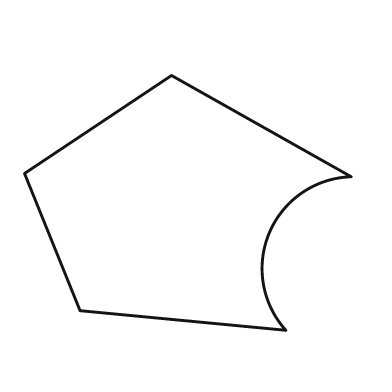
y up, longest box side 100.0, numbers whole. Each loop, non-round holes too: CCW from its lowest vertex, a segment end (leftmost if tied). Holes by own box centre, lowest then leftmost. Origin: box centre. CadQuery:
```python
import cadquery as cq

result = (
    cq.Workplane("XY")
    .moveTo(30.0, -39.0)
    .threePointArc((25.0, -9.0), (50.0, 8.0))
    .lineTo(-5.0, 39.0)
    .lineTo(-50.0, 9.0)
    .lineTo(-33.0, -33.0)
    .close()
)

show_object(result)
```